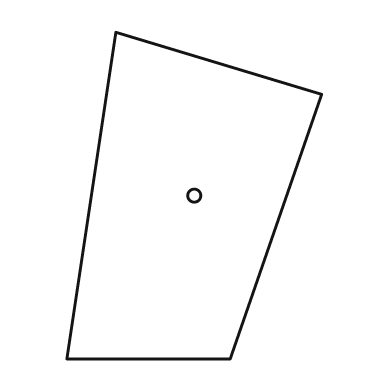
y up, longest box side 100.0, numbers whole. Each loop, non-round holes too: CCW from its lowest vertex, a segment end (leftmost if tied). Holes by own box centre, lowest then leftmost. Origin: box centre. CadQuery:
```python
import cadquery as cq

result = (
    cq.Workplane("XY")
    .moveTo(-39.0, -50.0)
    .lineTo(11.0, -50.0)
    .lineTo(39.0, 31.0)
    .lineTo(-24.0, 50.0)
    .close()
    .moveTo(0.0, 0.0)
    .circle(2.0)
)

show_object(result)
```